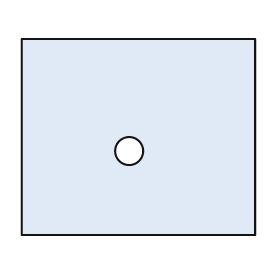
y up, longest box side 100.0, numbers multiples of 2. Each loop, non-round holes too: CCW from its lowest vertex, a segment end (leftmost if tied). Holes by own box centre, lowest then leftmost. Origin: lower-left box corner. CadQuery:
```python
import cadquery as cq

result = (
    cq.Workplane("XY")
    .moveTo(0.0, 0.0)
    .lineTo(100.0, 0.0)
    .lineTo(100.0, 84.0)
    .lineTo(0.0, 84.0)
    .close()
    .moveTo(46.0, 36.0)
    .circle(6.0)
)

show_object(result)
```